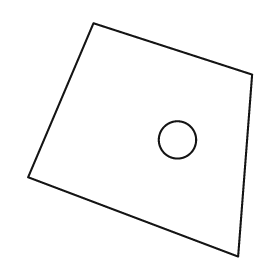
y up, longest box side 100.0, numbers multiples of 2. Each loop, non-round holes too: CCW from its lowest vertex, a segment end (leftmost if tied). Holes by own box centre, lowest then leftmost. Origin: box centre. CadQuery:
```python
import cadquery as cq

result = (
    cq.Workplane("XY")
    .moveTo(42.0, -50.0)
    .lineTo(48.0, 28.0)
    .lineTo(-20.0, 50.0)
    .lineTo(-48.0, -16.0)
    .close()
    .moveTo(16.0, 0.0)
    .circle(8.0)
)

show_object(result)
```